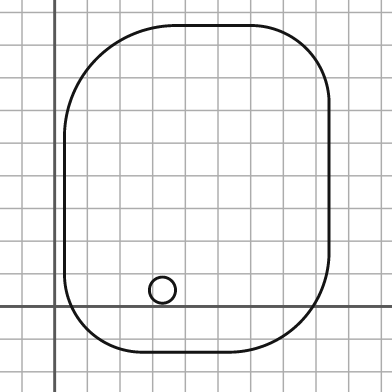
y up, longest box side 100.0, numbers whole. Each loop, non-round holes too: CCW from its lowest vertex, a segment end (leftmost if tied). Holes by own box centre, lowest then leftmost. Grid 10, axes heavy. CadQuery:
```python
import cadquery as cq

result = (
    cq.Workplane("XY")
    .moveTo(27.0, -14.0)
    .lineTo(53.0, -14.0)
    .threePointArc((75.0, -5.0), (84.0, 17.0))
    .lineTo(84.0, 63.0)
    .threePointArc((77.0, 79.0), (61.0, 86.0))
    .lineTo(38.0, 86.0)
    .threePointArc((13.0, 76.0), (3.0, 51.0))
    .lineTo(3.0, 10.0)
    .threePointArc((10.0, -7.0), (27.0, -14.0))
    .close()
    .moveTo(33.0, 5.0)
    .circle(4.0)
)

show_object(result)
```